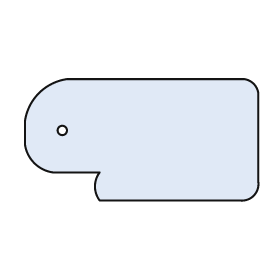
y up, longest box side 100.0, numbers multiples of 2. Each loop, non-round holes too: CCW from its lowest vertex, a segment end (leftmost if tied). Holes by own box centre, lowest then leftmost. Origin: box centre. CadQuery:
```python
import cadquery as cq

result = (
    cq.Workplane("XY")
    .moveTo(-18.0, -26.0)
    .lineTo(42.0, -26.0)
    .threePointArc((48.0, -24.0), (50.0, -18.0))
    .lineTo(50.0, 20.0)
    .threePointArc((48.0, 24.0), (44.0, 26.0))
    .lineTo(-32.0, 26.0)
    .threePointArc((-44.0, 20.0), (-50.0, 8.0))
    .lineTo(-50.0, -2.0)
    .threePointArc((-46.0, -10.0), (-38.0, -14.0))
    .lineTo(-18.0, -14.0)
    .threePointArc((-20.0, -20.0), (-18.0, -26.0))
    .close()
    .moveTo(-34.0, 4.0)
    .circle(2.0)
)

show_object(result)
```